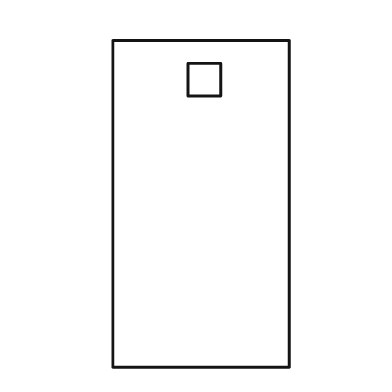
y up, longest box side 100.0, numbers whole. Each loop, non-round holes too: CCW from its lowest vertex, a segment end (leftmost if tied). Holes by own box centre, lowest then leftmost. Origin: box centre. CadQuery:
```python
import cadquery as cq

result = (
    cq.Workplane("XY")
    .moveTo(-27.0, -50.0)
    .lineTo(27.0, -50.0)
    .lineTo(27.0, 50.0)
    .lineTo(-27.0, 50.0)
    .close()
    .moveTo(-4.0, 33.0)
    .lineTo(6.0, 33.0)
    .lineTo(6.0, 43.0)
    .lineTo(-4.0, 43.0)
    .close()
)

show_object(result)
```